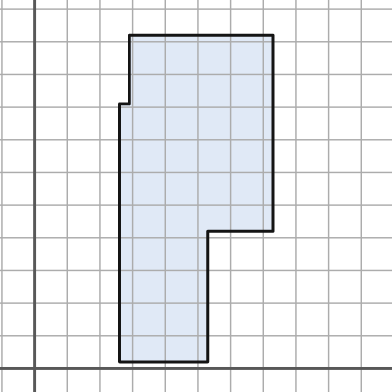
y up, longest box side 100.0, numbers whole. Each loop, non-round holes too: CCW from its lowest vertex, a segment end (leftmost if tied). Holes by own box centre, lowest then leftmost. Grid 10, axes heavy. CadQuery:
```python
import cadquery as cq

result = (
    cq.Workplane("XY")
    .moveTo(26.0, 2.0)
    .lineTo(53.0, 2.0)
    .lineTo(53.0, 42.0)
    .lineTo(73.0, 42.0)
    .lineTo(73.0, 102.0)
    .lineTo(29.0, 102.0)
    .lineTo(29.0, 81.0)
    .lineTo(26.0, 81.0)
    .close()
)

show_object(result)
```